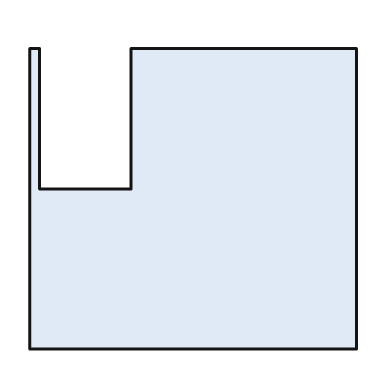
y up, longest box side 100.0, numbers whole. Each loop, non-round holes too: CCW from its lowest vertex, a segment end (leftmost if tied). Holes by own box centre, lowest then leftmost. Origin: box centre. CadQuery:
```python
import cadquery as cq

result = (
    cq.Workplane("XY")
    .moveTo(-50.0, -46.0)
    .lineTo(50.0, -46.0)
    .lineTo(50.0, 46.0)
    .lineTo(-19.0, 46.0)
    .lineTo(-19.0, 3.0)
    .lineTo(-47.0, 3.0)
    .lineTo(-47.0, 46.0)
    .lineTo(-50.0, 46.0)
    .close()
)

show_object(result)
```